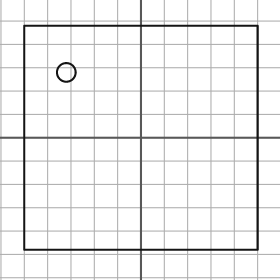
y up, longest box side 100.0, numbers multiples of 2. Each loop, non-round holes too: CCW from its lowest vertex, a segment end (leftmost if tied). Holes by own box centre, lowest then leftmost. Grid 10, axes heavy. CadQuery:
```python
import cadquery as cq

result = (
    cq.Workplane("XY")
    .moveTo(-50.0, -48.0)
    .lineTo(50.0, -48.0)
    .lineTo(50.0, 48.0)
    .lineTo(-50.0, 48.0)
    .close()
    .moveTo(-32.0, 28.0)
    .circle(4.0)
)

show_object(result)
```